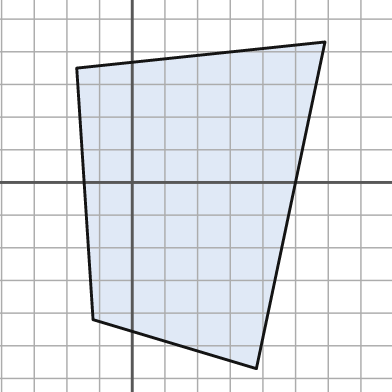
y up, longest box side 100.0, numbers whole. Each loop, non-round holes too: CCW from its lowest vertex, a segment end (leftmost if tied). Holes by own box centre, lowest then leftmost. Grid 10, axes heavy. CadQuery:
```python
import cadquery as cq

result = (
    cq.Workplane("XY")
    .moveTo(38.0, -57.0)
    .lineTo(59.0, 43.0)
    .lineTo(-17.0, 35.0)
    .lineTo(-12.0, -42.0)
    .close()
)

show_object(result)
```